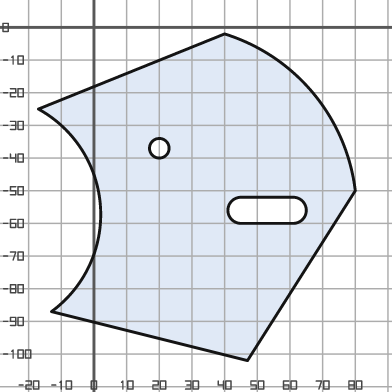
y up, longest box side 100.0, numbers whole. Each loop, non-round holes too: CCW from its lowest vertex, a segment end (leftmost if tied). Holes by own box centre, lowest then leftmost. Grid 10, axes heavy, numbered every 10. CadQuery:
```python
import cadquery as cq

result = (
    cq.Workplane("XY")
    .moveTo(47.0, -102.0)
    .lineTo(80.0, -50.0)
    .threePointArc((67.0, -20.0), (40.0, -2.0))
    .lineTo(-17.0, -25.0)
    .threePointArc((2.0, -55.0), (-13.0, -87.0))
    .close()
    .moveTo(45.0, -60.0)
    .lineTo(61.0, -60.0)
    .threePointArc((65.0, -56.0), (61.0, -52.0))
    .lineTo(45.0, -52.0)
    .threePointArc((41.0, -56.0), (45.0, -60.0))
    .close()
    .moveTo(20.0, -37.0)
    .circle(3.0)
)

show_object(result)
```